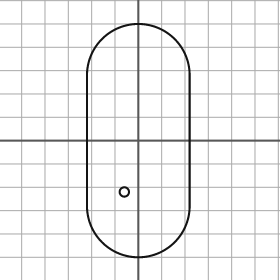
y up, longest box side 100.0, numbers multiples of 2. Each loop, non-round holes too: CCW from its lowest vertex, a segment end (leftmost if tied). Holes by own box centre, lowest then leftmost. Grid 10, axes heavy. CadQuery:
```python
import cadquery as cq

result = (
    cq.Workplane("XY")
    .moveTo(-22.0, -28.0)
    .threePointArc((0.0, -50.0), (22.0, -28.0))
    .lineTo(22.0, 28.0)
    .threePointArc((0.0, 50.0), (-22.0, 28.0))
    .close()
    .moveTo(-6.0, -22.0)
    .circle(2.0)
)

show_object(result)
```